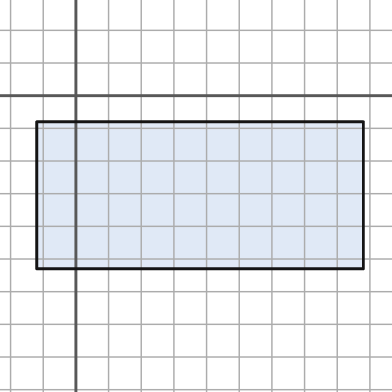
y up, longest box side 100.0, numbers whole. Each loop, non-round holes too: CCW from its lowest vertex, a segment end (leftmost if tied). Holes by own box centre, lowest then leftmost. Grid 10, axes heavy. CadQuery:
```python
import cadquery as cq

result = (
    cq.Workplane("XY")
    .moveTo(-12.0, -53.0)
    .lineTo(88.0, -53.0)
    .lineTo(88.0, -8.0)
    .lineTo(-12.0, -8.0)
    .close()
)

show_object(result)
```